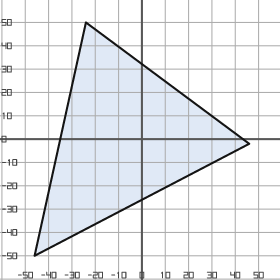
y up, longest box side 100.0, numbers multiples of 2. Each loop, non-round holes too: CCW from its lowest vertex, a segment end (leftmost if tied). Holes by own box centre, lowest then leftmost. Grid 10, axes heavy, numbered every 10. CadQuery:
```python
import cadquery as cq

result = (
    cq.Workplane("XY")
    .moveTo(-46.0, -50.0)
    .lineTo(46.0, -2.0)
    .lineTo(-24.0, 50.0)
    .close()
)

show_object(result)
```